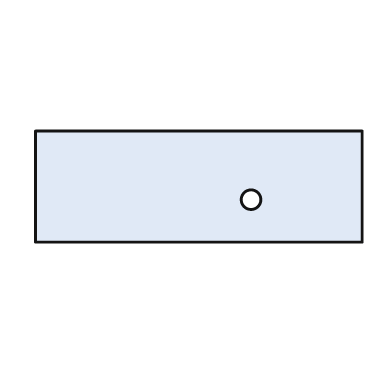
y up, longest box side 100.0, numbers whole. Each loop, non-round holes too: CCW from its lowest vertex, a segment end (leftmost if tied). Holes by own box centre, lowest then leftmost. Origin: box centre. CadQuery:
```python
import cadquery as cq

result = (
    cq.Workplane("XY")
    .moveTo(-50.0, -17.0)
    .lineTo(50.0, -17.0)
    .lineTo(50.0, 17.0)
    .lineTo(-50.0, 17.0)
    .close()
    .moveTo(16.0, -4.0)
    .circle(3.0)
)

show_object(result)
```